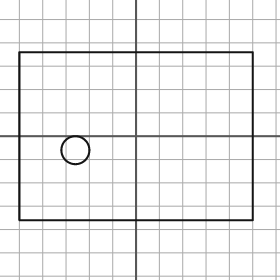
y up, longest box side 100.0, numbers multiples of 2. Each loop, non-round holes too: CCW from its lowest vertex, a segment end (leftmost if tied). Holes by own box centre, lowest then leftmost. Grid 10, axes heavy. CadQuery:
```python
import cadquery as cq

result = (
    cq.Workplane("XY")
    .moveTo(-50.0, -36.0)
    .lineTo(50.0, -36.0)
    .lineTo(50.0, 36.0)
    .lineTo(-50.0, 36.0)
    .close()
    .moveTo(-26.0, -6.0)
    .circle(6.0)
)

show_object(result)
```